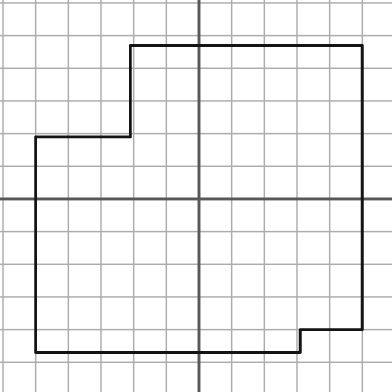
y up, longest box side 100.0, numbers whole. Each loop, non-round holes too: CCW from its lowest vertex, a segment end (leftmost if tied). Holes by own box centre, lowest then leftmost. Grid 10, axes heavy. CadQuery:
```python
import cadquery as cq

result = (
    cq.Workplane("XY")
    .moveTo(-50.0, -47.0)
    .lineTo(31.0, -47.0)
    .lineTo(31.0, -40.0)
    .lineTo(50.0, -40.0)
    .lineTo(50.0, 47.0)
    .lineTo(-21.0, 47.0)
    .lineTo(-21.0, 19.0)
    .lineTo(-50.0, 19.0)
    .close()
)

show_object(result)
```